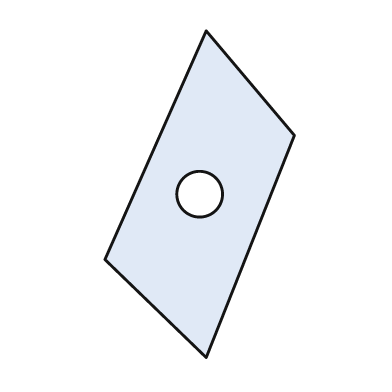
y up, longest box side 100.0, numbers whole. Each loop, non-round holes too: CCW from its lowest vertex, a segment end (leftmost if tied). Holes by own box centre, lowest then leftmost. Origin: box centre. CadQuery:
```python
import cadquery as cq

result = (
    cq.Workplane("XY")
    .moveTo(2.0, -50.0)
    .lineTo(29.0, 18.0)
    .lineTo(2.0, 50.0)
    .lineTo(-29.0, -20.0)
    .close()
    .moveTo(0.0, 0.0)
    .circle(7.0)
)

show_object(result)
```